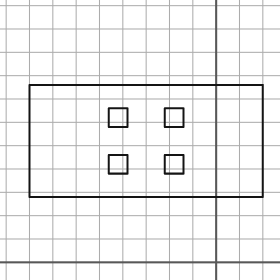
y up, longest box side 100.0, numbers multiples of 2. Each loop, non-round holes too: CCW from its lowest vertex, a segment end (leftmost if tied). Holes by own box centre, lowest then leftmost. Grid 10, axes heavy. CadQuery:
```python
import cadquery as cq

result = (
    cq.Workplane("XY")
    .moveTo(-80.0, 28.0)
    .lineTo(20.0, 28.0)
    .lineTo(20.0, 76.0)
    .lineTo(-80.0, 76.0)
    .close()
    .moveTo(-46.0, 38.0)
    .lineTo(-38.0, 38.0)
    .lineTo(-38.0, 46.0)
    .lineTo(-46.0, 46.0)
    .close()
    .moveTo(-22.0, 38.0)
    .lineTo(-14.0, 38.0)
    .lineTo(-14.0, 46.0)
    .lineTo(-22.0, 46.0)
    .close()
    .moveTo(-46.0, 58.0)
    .lineTo(-38.0, 58.0)
    .lineTo(-38.0, 66.0)
    .lineTo(-46.0, 66.0)
    .close()
    .moveTo(-22.0, 58.0)
    .lineTo(-14.0, 58.0)
    .lineTo(-14.0, 66.0)
    .lineTo(-22.0, 66.0)
    .close()
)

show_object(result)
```